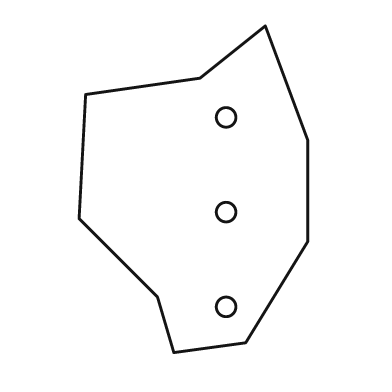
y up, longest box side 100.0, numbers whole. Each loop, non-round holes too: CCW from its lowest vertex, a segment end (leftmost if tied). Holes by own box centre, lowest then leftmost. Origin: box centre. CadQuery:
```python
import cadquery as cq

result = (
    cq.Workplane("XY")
    .moveTo(-6.0, -50.0)
    .lineTo(16.0, -47.0)
    .lineTo(35.0, -16.0)
    .lineTo(35.0, 15.0)
    .lineTo(22.0, 50.0)
    .lineTo(2.0, 34.0)
    .lineTo(-33.0, 29.0)
    .lineTo(-35.0, -9.0)
    .lineTo(-11.0, -33.0)
    .close()
    .moveTo(10.0, -36.0)
    .circle(3.0)
    .moveTo(10.0, -7.0)
    .circle(3.0)
    .moveTo(10.0, 22.0)
    .circle(3.0)
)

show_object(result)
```